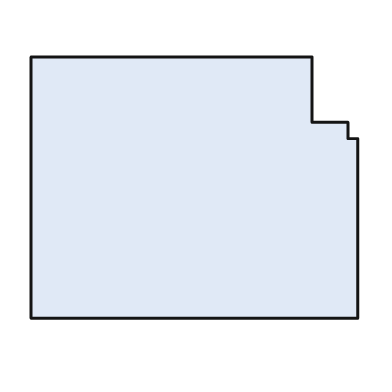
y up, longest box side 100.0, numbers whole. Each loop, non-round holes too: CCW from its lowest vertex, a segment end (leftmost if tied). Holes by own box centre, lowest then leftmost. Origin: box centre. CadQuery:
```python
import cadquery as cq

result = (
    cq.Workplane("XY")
    .moveTo(-50.0, -40.0)
    .lineTo(50.0, -40.0)
    .lineTo(50.0, 15.0)
    .lineTo(47.0, 15.0)
    .lineTo(47.0, 20.0)
    .lineTo(36.0, 20.0)
    .lineTo(36.0, 40.0)
    .lineTo(-50.0, 40.0)
    .close()
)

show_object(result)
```